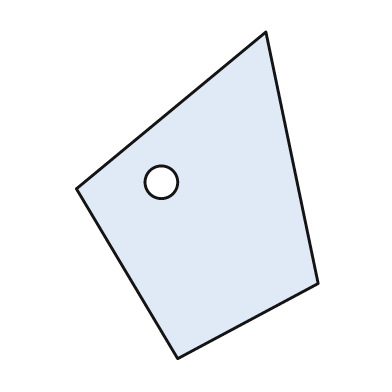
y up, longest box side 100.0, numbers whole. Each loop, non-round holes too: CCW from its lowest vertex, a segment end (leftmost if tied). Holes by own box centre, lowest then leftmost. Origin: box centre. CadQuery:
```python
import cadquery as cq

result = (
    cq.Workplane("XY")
    .moveTo(-6.0, -50.0)
    .lineTo(37.0, -27.0)
    .lineTo(21.0, 50.0)
    .lineTo(-37.0, 2.0)
    .close()
    .moveTo(-11.0, 4.0)
    .circle(5.0)
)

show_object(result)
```